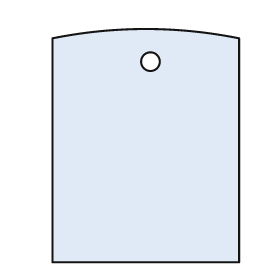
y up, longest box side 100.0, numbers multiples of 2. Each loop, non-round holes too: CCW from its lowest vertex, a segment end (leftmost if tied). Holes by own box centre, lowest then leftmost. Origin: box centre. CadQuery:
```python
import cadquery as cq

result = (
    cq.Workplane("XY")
    .moveTo(-40.0, -50.0)
    .lineTo(40.0, -50.0)
    .lineTo(40.0, 46.0)
    .threePointArc((0.0, 50.0), (-40.0, 46.0))
    .close()
    .moveTo(2.0, 36.0)
    .circle(4.0)
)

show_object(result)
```